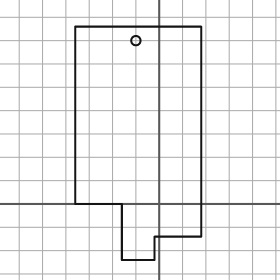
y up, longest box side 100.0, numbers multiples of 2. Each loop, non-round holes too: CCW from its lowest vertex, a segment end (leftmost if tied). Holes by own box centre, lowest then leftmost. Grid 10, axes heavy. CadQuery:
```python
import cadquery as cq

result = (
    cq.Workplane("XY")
    .moveTo(-16.0, -24.0)
    .lineTo(-2.0, -24.0)
    .lineTo(-2.0, -14.0)
    .lineTo(18.0, -14.0)
    .lineTo(18.0, 76.0)
    .lineTo(-36.0, 76.0)
    .lineTo(-36.0, 0.0)
    .lineTo(-16.0, 0.0)
    .close()
    .moveTo(-10.0, 70.0)
    .circle(2.0)
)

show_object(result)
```